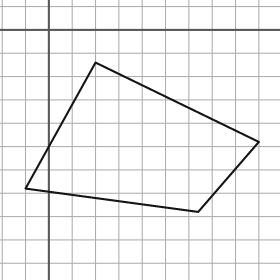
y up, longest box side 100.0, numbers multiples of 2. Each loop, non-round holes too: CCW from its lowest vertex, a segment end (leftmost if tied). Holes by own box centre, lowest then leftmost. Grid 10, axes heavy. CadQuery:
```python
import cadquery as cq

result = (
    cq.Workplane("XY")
    .moveTo(64.0, -78.0)
    .lineTo(90.0, -48.0)
    .lineTo(20.0, -14.0)
    .lineTo(-10.0, -68.0)
    .close()
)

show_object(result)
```